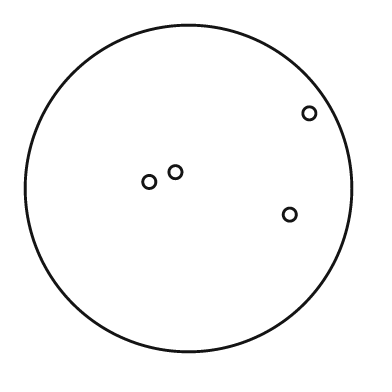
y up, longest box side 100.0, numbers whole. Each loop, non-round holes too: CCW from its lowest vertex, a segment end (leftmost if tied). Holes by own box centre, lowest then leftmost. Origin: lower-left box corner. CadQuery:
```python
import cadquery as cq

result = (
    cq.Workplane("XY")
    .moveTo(50.0, 50.0)
    .circle(50.0)
    .moveTo(81.0, 42.0)
    .circle(2.0)
    .moveTo(38.0, 52.0)
    .circle(2.0)
    .moveTo(46.0, 55.0)
    .circle(2.0)
    .moveTo(87.0, 73.0)
    .circle(2.0)
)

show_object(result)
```